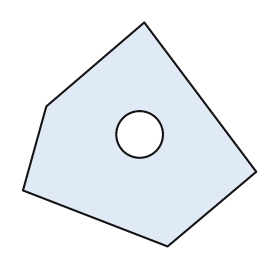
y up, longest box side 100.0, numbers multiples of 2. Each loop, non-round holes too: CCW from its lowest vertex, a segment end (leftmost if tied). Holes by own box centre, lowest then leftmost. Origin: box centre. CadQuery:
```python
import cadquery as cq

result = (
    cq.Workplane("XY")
    .moveTo(12.0, -48.0)
    .lineTo(50.0, -16.0)
    .lineTo(2.0, 48.0)
    .lineTo(-40.0, 12.0)
    .lineTo(-50.0, -24.0)
    .close()
    .moveTo(0.0, 0.0)
    .circle(10.0)
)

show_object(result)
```